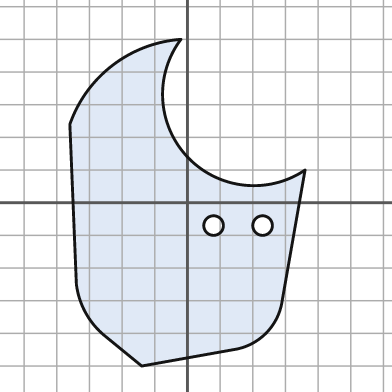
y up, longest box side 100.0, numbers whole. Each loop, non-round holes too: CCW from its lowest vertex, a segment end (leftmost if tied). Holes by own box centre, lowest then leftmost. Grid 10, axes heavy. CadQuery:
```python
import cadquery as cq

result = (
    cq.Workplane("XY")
    .moveTo(-14.0, -50.0)
    .lineTo(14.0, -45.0)
    .threePointArc((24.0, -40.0), (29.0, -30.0))
    .lineTo(36.0, 10.0)
    .threePointArc((0.0, 14.0), (-2.0, 50.0))
    .threePointArc((-23.0, 42.0), (-36.0, 24.0))
    .lineTo(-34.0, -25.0)
    .threePointArc((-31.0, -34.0), (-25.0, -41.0))
    .close()
    .moveTo(8.0, -7.0)
    .circle(3.0)
    .moveTo(23.0, -7.0)
    .circle(3.0)
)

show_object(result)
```